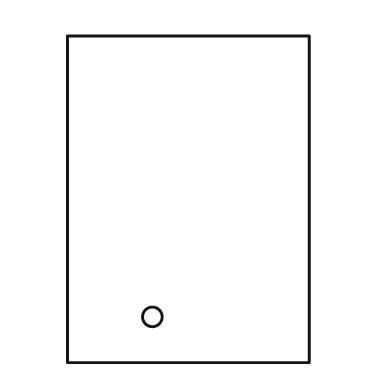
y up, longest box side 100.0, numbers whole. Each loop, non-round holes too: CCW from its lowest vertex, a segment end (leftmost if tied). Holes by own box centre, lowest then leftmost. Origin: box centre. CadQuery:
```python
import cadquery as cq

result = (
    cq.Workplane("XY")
    .moveTo(-37.0, -50.0)
    .lineTo(37.0, -50.0)
    .lineTo(37.0, 50.0)
    .lineTo(-37.0, 50.0)
    .close()
    .moveTo(-11.0, -36.0)
    .circle(3.0)
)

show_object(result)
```